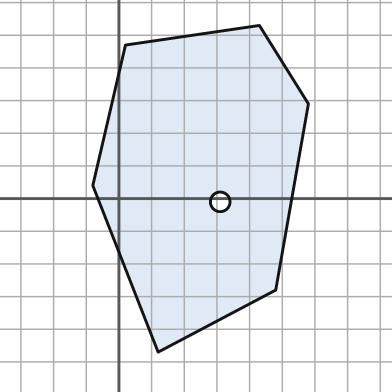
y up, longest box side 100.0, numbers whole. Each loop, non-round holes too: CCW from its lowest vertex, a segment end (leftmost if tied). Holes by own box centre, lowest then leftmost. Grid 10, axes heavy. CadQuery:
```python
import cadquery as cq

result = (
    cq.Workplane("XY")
    .moveTo(12.0, -47.0)
    .lineTo(48.0, -28.0)
    .lineTo(58.0, 29.0)
    .lineTo(43.0, 53.0)
    .lineTo(2.0, 47.0)
    .lineTo(-8.0, 4.0)
    .close()
    .moveTo(31.0, -1.0)
    .circle(3.0)
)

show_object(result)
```